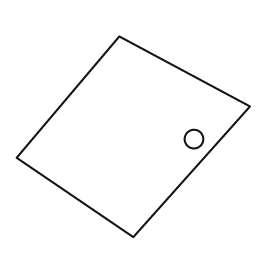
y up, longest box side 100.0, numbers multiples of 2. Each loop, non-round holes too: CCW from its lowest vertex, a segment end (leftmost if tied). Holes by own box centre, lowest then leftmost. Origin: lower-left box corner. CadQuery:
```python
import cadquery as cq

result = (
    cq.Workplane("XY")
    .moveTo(50.0, 0.0)
    .lineTo(100.0, 56.0)
    .lineTo(44.0, 86.0)
    .lineTo(0.0, 34.0)
    .close()
    .moveTo(76.0, 42.0)
    .circle(4.0)
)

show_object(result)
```